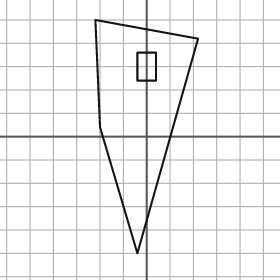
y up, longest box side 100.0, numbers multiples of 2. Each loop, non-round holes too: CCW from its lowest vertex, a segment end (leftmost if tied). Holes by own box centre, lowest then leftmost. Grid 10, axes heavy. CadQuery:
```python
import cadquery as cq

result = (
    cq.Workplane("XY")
    .moveTo(-4.0, -50.0)
    .lineTo(22.0, 42.0)
    .lineTo(-22.0, 50.0)
    .lineTo(-20.0, 4.0)
    .close()
    .moveTo(-4.0, 24.0)
    .lineTo(4.0, 24.0)
    .lineTo(4.0, 36.0)
    .lineTo(-4.0, 36.0)
    .close()
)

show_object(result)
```